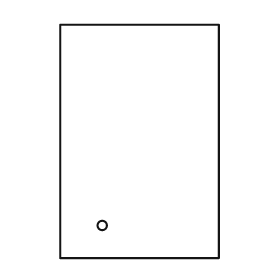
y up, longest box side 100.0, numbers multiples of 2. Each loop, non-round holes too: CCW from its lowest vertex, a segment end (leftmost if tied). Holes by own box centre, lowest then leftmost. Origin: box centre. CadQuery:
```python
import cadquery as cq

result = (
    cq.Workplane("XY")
    .moveTo(-34.0, -50.0)
    .lineTo(34.0, -50.0)
    .lineTo(34.0, 50.0)
    .lineTo(-34.0, 50.0)
    .close()
    .moveTo(-16.0, -36.0)
    .circle(2.0)
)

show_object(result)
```